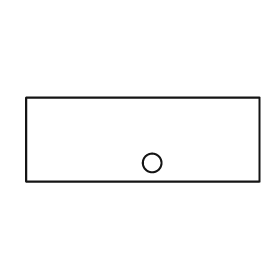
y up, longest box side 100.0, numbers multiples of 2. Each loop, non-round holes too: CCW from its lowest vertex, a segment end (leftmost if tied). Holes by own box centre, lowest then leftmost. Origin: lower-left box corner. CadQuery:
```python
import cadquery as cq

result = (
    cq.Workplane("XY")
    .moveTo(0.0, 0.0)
    .lineTo(100.0, 0.0)
    .lineTo(100.0, 36.0)
    .lineTo(0.0, 36.0)
    .close()
    .moveTo(54.0, 8.0)
    .circle(4.0)
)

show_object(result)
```